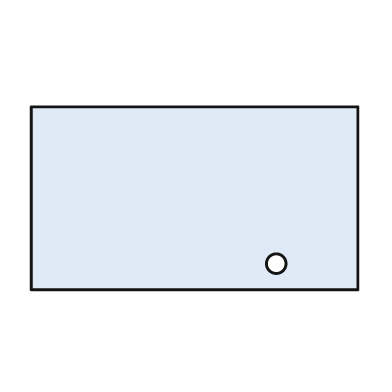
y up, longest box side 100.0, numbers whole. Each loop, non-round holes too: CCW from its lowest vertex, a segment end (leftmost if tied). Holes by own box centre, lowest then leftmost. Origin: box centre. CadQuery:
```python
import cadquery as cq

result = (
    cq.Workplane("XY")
    .moveTo(-50.0, -28.0)
    .lineTo(50.0, -28.0)
    .lineTo(50.0, 28.0)
    .lineTo(-50.0, 28.0)
    .close()
    .moveTo(25.0, -20.0)
    .circle(3.0)
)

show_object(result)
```